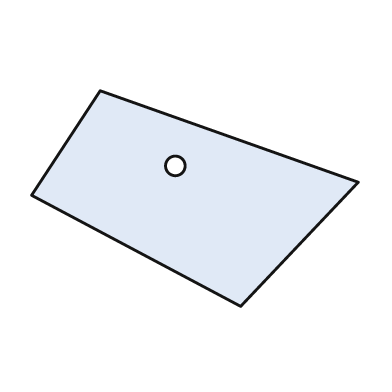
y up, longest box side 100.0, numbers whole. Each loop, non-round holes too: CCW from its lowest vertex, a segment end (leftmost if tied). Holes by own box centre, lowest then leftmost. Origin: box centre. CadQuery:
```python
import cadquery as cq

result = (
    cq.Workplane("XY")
    .moveTo(14.0, -33.0)
    .lineTo(50.0, 5.0)
    .lineTo(-29.0, 33.0)
    .lineTo(-50.0, 1.0)
    .close()
    .moveTo(-6.0, 10.0)
    .circle(3.0)
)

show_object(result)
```